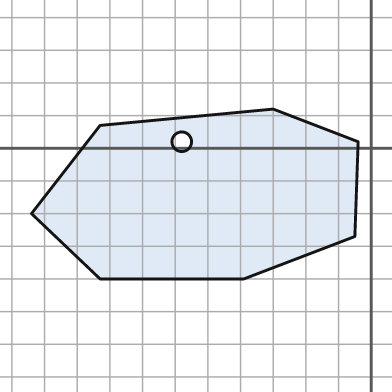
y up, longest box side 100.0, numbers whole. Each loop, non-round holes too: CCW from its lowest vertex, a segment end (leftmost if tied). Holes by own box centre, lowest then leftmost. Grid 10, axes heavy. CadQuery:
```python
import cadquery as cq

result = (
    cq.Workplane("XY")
    .moveTo(-83.0, -40.0)
    .lineTo(-39.0, -40.0)
    .lineTo(-5.0, -27.0)
    .lineTo(-4.0, 2.0)
    .lineTo(-30.0, 12.0)
    .lineTo(-83.0, 7.0)
    .lineTo(-104.0, -20.0)
    .close()
    .moveTo(-58.0, 2.0)
    .circle(3.0)
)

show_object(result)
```